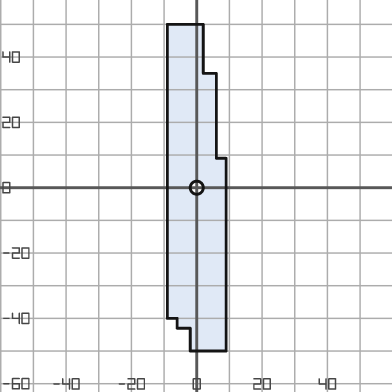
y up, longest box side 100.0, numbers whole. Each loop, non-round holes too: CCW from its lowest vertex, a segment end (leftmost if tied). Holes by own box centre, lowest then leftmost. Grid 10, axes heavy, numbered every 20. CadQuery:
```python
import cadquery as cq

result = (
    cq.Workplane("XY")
    .moveTo(-2.0, -50.0)
    .lineTo(9.0, -50.0)
    .lineTo(9.0, 9.0)
    .lineTo(6.0, 9.0)
    .lineTo(6.0, 35.0)
    .lineTo(2.0, 35.0)
    .lineTo(2.0, 50.0)
    .lineTo(-9.0, 50.0)
    .lineTo(-9.0, -40.0)
    .lineTo(-6.0, -40.0)
    .lineTo(-6.0, -43.0)
    .lineTo(-2.0, -43.0)
    .close()
    .moveTo(0.0, 0.0)
    .circle(2.0)
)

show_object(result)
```